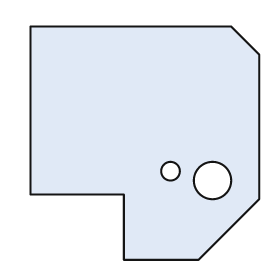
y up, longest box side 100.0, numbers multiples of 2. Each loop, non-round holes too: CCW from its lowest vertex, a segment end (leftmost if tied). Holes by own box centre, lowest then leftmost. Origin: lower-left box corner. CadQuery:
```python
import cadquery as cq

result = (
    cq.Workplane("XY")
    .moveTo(40.0, 0.0)
    .lineTo(72.0, 0.0)
    .lineTo(98.0, 26.0)
    .lineTo(98.0, 88.0)
    .lineTo(86.0, 100.0)
    .lineTo(0.0, 100.0)
    .lineTo(0.0, 28.0)
    .lineTo(40.0, 28.0)
    .close()
    .moveTo(78.0, 34.0)
    .circle(8.0)
    .moveTo(60.0, 38.0)
    .circle(4.0)
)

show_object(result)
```